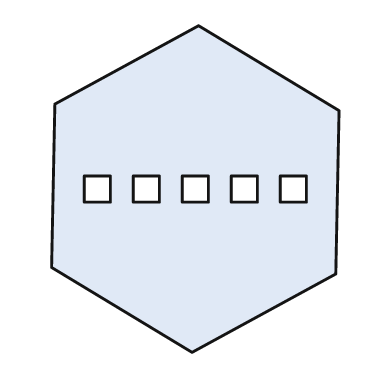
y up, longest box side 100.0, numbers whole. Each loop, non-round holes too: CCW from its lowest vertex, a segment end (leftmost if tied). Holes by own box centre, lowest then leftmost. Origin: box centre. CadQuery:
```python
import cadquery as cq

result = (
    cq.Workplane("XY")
    .moveTo(-1.0, -50.0)
    .lineTo(43.0, -26.0)
    .lineTo(44.0, 24.0)
    .lineTo(1.0, 50.0)
    .lineTo(-43.0, 26.0)
    .lineTo(-44.0, -24.0)
    .close()
    .moveTo(-34.0, -4.0)
    .lineTo(-26.0, -4.0)
    .lineTo(-26.0, 4.0)
    .lineTo(-34.0, 4.0)
    .close()
    .moveTo(-19.0, -4.0)
    .lineTo(-11.0, -4.0)
    .lineTo(-11.0, 4.0)
    .lineTo(-19.0, 4.0)
    .close()
    .moveTo(-4.0, -4.0)
    .lineTo(4.0, -4.0)
    .lineTo(4.0, 4.0)
    .lineTo(-4.0, 4.0)
    .close()
    .moveTo(11.0, -4.0)
    .lineTo(19.0, -4.0)
    .lineTo(19.0, 4.0)
    .lineTo(11.0, 4.0)
    .close()
    .moveTo(26.0, -4.0)
    .lineTo(34.0, -4.0)
    .lineTo(34.0, 4.0)
    .lineTo(26.0, 4.0)
    .close()
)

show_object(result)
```